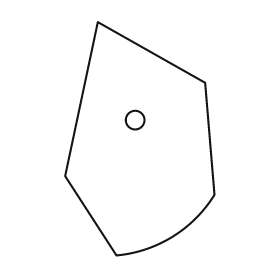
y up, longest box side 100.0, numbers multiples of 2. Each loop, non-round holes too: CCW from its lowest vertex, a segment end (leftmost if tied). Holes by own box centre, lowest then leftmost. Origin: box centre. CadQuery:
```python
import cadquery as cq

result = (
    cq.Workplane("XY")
    .moveTo(-10.0, -50.0)
    .threePointArc((14.0, -42.0), (32.0, -24.0))
    .lineTo(28.0, 24.0)
    .lineTo(-18.0, 50.0)
    .lineTo(-32.0, -16.0)
    .close()
    .moveTo(-2.0, 8.0)
    .circle(4.0)
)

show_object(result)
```